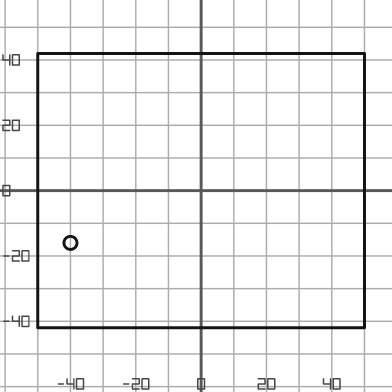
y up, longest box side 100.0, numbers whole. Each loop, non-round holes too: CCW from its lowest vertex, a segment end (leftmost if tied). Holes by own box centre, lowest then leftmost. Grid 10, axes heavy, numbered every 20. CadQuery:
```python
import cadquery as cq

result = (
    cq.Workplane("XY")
    .moveTo(-50.0, -42.0)
    .lineTo(50.0, -42.0)
    .lineTo(50.0, 42.0)
    .lineTo(-50.0, 42.0)
    .close()
    .moveTo(-40.0, -16.0)
    .circle(2.0)
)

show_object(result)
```